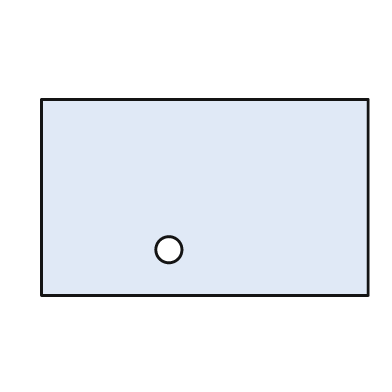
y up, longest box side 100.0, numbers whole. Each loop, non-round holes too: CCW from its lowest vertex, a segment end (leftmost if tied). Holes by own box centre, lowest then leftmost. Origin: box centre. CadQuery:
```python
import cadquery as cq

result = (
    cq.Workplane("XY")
    .moveTo(-50.0, -30.0)
    .lineTo(50.0, -30.0)
    .lineTo(50.0, 30.0)
    .lineTo(-50.0, 30.0)
    .close()
    .moveTo(-11.0, -16.0)
    .circle(4.0)
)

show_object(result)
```